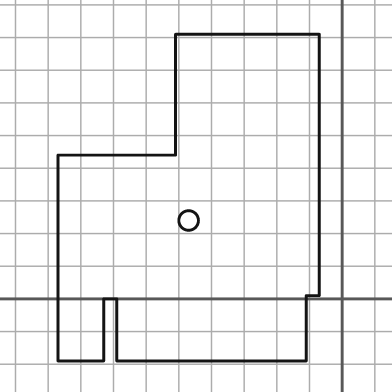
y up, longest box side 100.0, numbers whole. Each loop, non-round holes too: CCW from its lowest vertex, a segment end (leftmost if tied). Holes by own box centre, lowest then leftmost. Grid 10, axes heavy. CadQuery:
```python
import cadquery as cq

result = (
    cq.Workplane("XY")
    .moveTo(-87.0, -19.0)
    .lineTo(-73.0, -19.0)
    .lineTo(-73.0, 0.0)
    .lineTo(-69.0, 0.0)
    .lineTo(-69.0, -19.0)
    .lineTo(-11.0, -19.0)
    .lineTo(-11.0, 1.0)
    .lineTo(-7.0, 1.0)
    .lineTo(-7.0, 81.0)
    .lineTo(-51.0, 81.0)
    .lineTo(-51.0, 44.0)
    .lineTo(-87.0, 44.0)
    .close()
    .moveTo(-47.0, 24.0)
    .circle(3.0)
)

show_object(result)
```